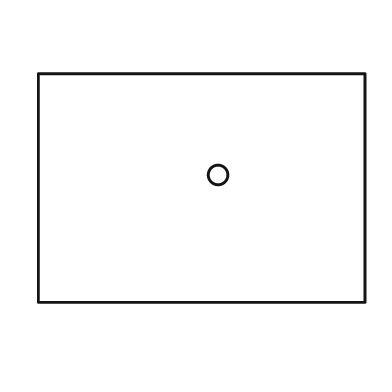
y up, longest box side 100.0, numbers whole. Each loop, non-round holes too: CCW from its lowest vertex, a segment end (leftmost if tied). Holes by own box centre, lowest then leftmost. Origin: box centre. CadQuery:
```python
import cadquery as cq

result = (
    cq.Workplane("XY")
    .moveTo(-50.0, -35.0)
    .lineTo(50.0, -35.0)
    .lineTo(50.0, 35.0)
    .lineTo(-50.0, 35.0)
    .close()
    .moveTo(5.0, 4.0)
    .circle(3.0)
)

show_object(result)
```